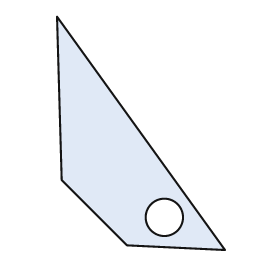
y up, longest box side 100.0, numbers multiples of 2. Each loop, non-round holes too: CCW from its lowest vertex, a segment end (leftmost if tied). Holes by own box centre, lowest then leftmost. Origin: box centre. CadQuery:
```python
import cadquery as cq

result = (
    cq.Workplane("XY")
    .moveTo(36.0, -50.0)
    .lineTo(-36.0, 50.0)
    .lineTo(-34.0, -20.0)
    .lineTo(-6.0, -48.0)
    .close()
    .moveTo(10.0, -36.0)
    .circle(8.0)
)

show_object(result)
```